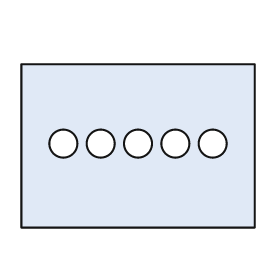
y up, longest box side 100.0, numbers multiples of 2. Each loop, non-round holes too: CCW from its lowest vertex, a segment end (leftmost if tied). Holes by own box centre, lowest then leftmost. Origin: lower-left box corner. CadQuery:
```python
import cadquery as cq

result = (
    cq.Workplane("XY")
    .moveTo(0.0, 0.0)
    .lineTo(100.0, 0.0)
    .lineTo(100.0, 70.0)
    .lineTo(0.0, 70.0)
    .close()
    .moveTo(18.0, 36.0)
    .circle(6.0)
    .moveTo(34.0, 36.0)
    .circle(6.0)
    .moveTo(50.0, 36.0)
    .circle(6.0)
    .moveTo(66.0, 36.0)
    .circle(6.0)
    .moveTo(82.0, 36.0)
    .circle(6.0)
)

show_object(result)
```